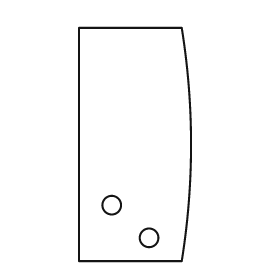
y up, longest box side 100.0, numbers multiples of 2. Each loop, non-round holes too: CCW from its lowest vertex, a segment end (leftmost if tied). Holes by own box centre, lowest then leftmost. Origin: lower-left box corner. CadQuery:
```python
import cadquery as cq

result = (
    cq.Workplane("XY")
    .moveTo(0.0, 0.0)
    .lineTo(44.0, 0.0)
    .threePointArc((48.0, 50.0), (44.0, 100.0))
    .lineTo(0.0, 100.0)
    .close()
    .moveTo(30.0, 10.0)
    .circle(4.0)
    .moveTo(14.0, 24.0)
    .circle(4.0)
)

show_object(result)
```